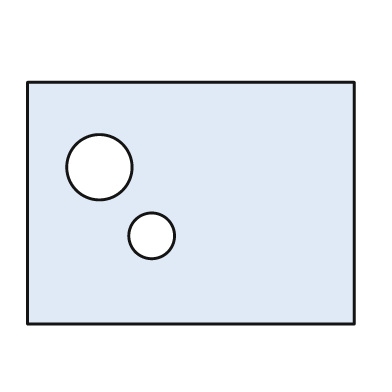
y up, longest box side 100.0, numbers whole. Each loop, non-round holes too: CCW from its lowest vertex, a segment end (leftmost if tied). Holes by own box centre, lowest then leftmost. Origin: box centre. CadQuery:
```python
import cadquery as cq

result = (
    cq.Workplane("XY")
    .moveTo(-50.0, -37.0)
    .lineTo(50.0, -37.0)
    .lineTo(50.0, 37.0)
    .lineTo(-50.0, 37.0)
    .close()
    .moveTo(-12.0, -10.0)
    .circle(7.0)
    .moveTo(-28.0, 11.0)
    .circle(10.0)
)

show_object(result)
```